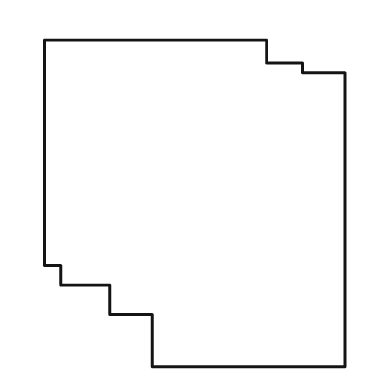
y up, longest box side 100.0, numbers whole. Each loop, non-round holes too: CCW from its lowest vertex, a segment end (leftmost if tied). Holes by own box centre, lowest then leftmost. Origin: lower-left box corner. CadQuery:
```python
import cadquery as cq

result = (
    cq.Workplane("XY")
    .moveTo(33.0, 0.0)
    .lineTo(92.0, 0.0)
    .lineTo(92.0, 90.0)
    .lineTo(79.0, 90.0)
    .lineTo(79.0, 93.0)
    .lineTo(68.0, 93.0)
    .lineTo(68.0, 100.0)
    .lineTo(0.0, 100.0)
    .lineTo(0.0, 31.0)
    .lineTo(5.0, 31.0)
    .lineTo(5.0, 25.0)
    .lineTo(20.0, 25.0)
    .lineTo(20.0, 16.0)
    .lineTo(33.0, 16.0)
    .close()
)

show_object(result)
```